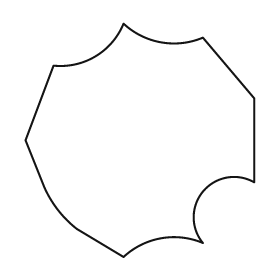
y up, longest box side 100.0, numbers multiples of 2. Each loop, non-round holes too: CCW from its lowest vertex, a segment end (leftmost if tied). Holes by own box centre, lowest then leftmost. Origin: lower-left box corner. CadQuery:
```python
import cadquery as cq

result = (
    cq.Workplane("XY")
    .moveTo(42.0, 0.0)
    .threePointArc((58.0, 8.0), (76.0, 6.0))
    .threePointArc((76.0, 28.0), (98.0, 32.0))
    .lineTo(98.0, 68.0)
    .lineTo(76.0, 94.0)
    .threePointArc((58.0, 92.0), (42.0, 100.0))
    .threePointArc((30.0, 86.0), (12.0, 82.0))
    .lineTo(0.0, 50.0)
    .lineTo(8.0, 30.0)
    .threePointArc((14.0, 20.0), (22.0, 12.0))
    .close()
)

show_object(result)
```